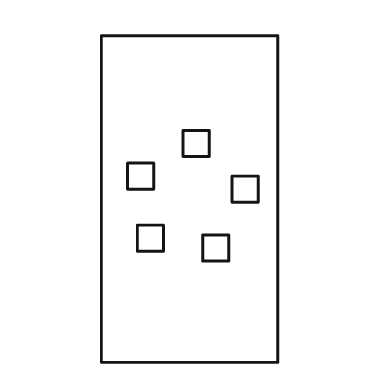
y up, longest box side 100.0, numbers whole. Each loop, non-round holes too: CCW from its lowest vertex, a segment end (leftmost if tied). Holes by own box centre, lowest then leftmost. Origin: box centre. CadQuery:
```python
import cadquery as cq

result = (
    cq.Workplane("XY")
    .moveTo(-27.0, -50.0)
    .lineTo(27.0, -50.0)
    .lineTo(27.0, 50.0)
    .lineTo(-27.0, 50.0)
    .close()
    .moveTo(4.0, -19.0)
    .lineTo(12.0, -19.0)
    .lineTo(12.0, -11.0)
    .lineTo(4.0, -11.0)
    .close()
    .moveTo(-16.0, -16.0)
    .lineTo(-8.0, -16.0)
    .lineTo(-8.0, -8.0)
    .lineTo(-16.0, -8.0)
    .close()
    .moveTo(13.0, -1.0)
    .lineTo(21.0, -1.0)
    .lineTo(21.0, 7.0)
    .lineTo(13.0, 7.0)
    .close()
    .moveTo(-19.0, 3.0)
    .lineTo(-11.0, 3.0)
    .lineTo(-11.0, 11.0)
    .lineTo(-19.0, 11.0)
    .close()
    .moveTo(-2.0, 13.0)
    .lineTo(6.0, 13.0)
    .lineTo(6.0, 21.0)
    .lineTo(-2.0, 21.0)
    .close()
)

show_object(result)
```